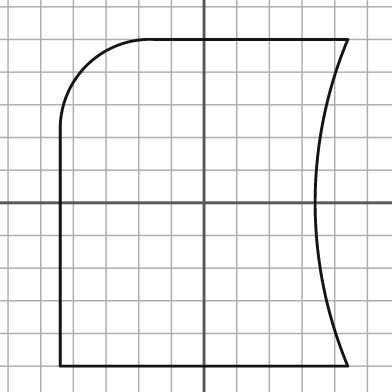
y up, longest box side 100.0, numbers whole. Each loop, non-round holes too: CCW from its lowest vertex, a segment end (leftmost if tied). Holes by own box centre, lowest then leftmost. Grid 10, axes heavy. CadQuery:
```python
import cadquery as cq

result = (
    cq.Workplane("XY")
    .moveTo(-44.0, -50.0)
    .lineTo(44.0, -50.0)
    .threePointArc((34.0, 0.0), (44.0, 50.0))
    .lineTo(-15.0, 50.0)
    .threePointArc((-36.0, 42.0), (-44.0, 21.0))
    .close()
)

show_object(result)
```